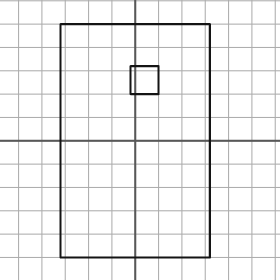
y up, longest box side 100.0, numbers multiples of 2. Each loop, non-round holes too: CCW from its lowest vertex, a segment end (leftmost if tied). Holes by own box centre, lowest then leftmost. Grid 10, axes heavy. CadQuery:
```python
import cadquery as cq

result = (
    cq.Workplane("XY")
    .moveTo(-32.0, -50.0)
    .lineTo(32.0, -50.0)
    .lineTo(32.0, 50.0)
    .lineTo(-32.0, 50.0)
    .close()
    .moveTo(-2.0, 20.0)
    .lineTo(10.0, 20.0)
    .lineTo(10.0, 32.0)
    .lineTo(-2.0, 32.0)
    .close()
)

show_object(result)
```